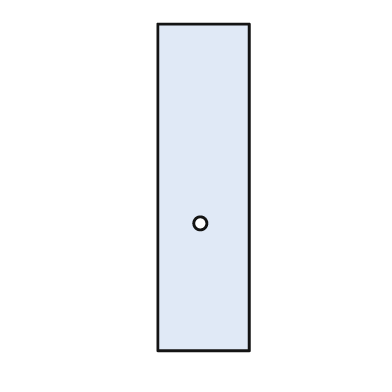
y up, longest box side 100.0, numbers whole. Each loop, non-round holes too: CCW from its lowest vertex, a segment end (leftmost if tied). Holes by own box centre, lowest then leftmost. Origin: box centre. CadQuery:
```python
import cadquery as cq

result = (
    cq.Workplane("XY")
    .moveTo(-14.0, -50.0)
    .lineTo(14.0, -50.0)
    .lineTo(14.0, 50.0)
    .lineTo(-14.0, 50.0)
    .close()
    .moveTo(-1.0, -11.0)
    .circle(2.0)
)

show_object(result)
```